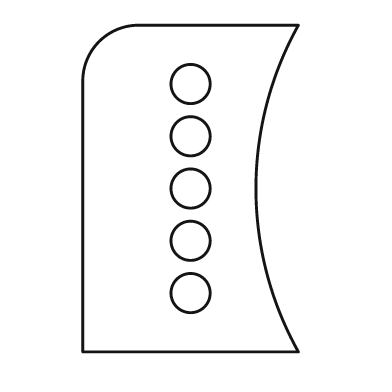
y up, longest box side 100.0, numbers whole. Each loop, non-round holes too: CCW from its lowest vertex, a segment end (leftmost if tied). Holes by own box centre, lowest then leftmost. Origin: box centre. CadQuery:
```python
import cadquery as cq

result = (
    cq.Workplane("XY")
    .moveTo(-33.0, -50.0)
    .lineTo(33.0, -50.0)
    .threePointArc((20.0, 0.0), (33.0, 50.0))
    .lineTo(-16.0, 50.0)
    .threePointArc((-28.0, 45.0), (-33.0, 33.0))
    .close()
    .moveTo(0.0, -32.0)
    .circle(6.0)
    .moveTo(0.0, -16.0)
    .circle(6.0)
    .moveTo(0.0, 0.0)
    .circle(6.0)
    .moveTo(0.0, 16.0)
    .circle(6.0)
    .moveTo(0.0, 32.0)
    .circle(6.0)
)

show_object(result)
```